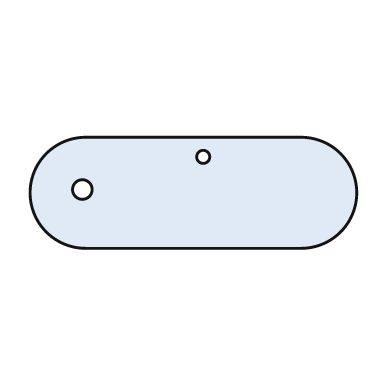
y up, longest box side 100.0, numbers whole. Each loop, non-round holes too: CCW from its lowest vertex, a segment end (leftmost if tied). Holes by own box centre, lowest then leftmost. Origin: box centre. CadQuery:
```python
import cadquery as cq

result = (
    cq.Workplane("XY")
    .moveTo(-33.0, -17.0)
    .lineTo(33.0, -17.0)
    .threePointArc((50.0, 0.0), (33.0, 17.0))
    .lineTo(-33.0, 17.0)
    .threePointArc((-50.0, 0.0), (-33.0, -17.0))
    .close()
    .moveTo(-34.0, 1.0)
    .circle(3.0)
    .moveTo(3.0, 11.0)
    .circle(2.0)
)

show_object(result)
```